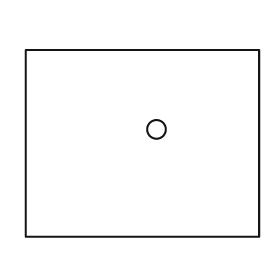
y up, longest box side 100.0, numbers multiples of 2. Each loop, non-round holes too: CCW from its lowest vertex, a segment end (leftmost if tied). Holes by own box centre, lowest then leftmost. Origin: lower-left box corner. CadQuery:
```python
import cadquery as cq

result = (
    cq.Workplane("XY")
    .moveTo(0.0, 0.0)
    .lineTo(100.0, 0.0)
    .lineTo(100.0, 80.0)
    .lineTo(0.0, 80.0)
    .close()
    .moveTo(56.0, 46.0)
    .circle(4.0)
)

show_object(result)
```